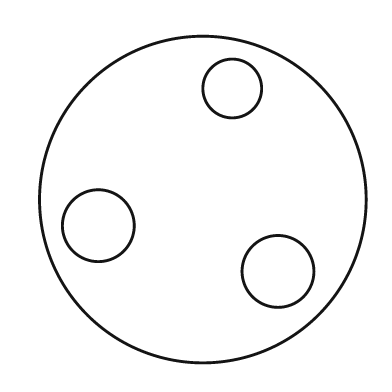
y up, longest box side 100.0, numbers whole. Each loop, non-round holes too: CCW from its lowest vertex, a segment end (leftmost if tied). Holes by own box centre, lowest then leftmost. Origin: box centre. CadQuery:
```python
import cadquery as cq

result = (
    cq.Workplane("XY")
    .moveTo(0.0, 0.0)
    .circle(50.0)
    .moveTo(23.0, -22.0)
    .circle(11.0)
    .moveTo(-32.0, -8.0)
    .circle(11.0)
    .moveTo(9.0, 34.0)
    .circle(9.0)
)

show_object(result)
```